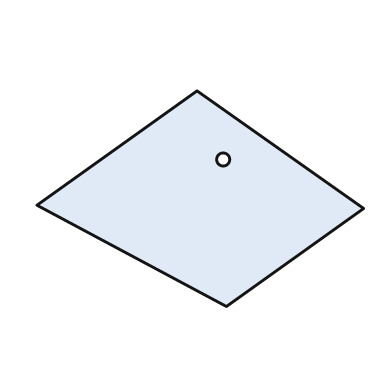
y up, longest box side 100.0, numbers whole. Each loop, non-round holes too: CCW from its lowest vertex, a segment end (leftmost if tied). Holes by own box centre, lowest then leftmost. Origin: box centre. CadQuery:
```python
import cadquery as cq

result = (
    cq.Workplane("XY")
    .moveTo(8.0, -33.0)
    .lineTo(50.0, -3.0)
    .lineTo(-1.0, 33.0)
    .lineTo(-50.0, -2.0)
    .close()
    .moveTo(7.0, 12.0)
    .circle(2.0)
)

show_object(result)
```